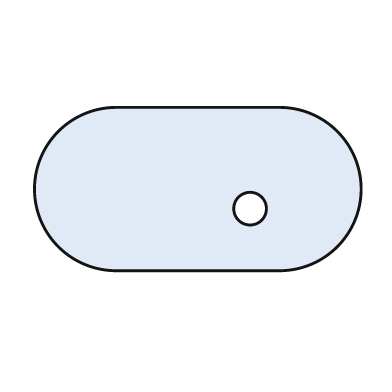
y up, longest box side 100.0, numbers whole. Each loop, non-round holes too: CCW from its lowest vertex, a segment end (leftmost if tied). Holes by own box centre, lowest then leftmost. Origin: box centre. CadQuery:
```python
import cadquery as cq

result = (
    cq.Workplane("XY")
    .moveTo(-25.0, -25.0)
    .lineTo(25.0, -25.0)
    .threePointArc((50.0, 0.0), (25.0, 25.0))
    .lineTo(-25.0, 25.0)
    .threePointArc((-50.0, 0.0), (-25.0, -25.0))
    .close()
    .moveTo(16.0, -6.0)
    .circle(5.0)
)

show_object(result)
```